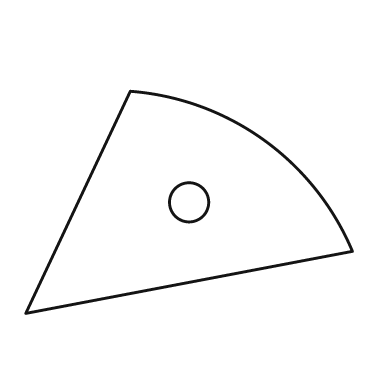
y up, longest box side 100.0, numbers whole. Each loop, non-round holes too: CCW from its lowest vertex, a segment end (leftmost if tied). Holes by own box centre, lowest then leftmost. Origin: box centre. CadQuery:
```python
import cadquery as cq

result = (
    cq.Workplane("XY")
    .moveTo(-50.0, -34.0)
    .lineTo(50.0, -15.0)
    .threePointArc((23.0, 19.0), (-18.0, 34.0))
    .close()
    .moveTo(0.0, 0.0)
    .circle(6.0)
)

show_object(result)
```